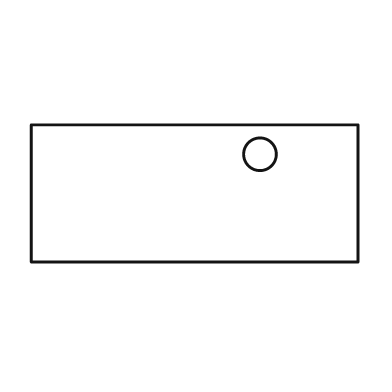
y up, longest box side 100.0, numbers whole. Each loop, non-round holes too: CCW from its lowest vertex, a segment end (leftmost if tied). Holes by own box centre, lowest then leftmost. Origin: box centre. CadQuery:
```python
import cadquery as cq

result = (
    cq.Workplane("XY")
    .moveTo(-50.0, -21.0)
    .lineTo(50.0, -21.0)
    .lineTo(50.0, 21.0)
    .lineTo(-50.0, 21.0)
    .close()
    .moveTo(20.0, 12.0)
    .circle(5.0)
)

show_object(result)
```